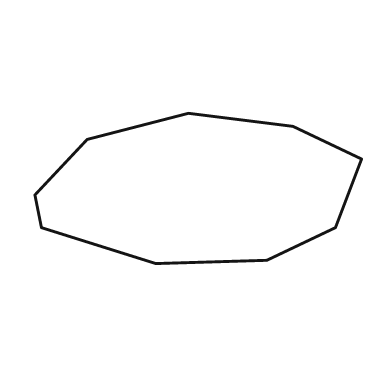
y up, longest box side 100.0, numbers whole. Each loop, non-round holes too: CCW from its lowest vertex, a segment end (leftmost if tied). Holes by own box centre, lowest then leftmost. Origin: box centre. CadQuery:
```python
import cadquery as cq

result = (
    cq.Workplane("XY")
    .moveTo(-13.0, -23.0)
    .lineTo(21.0, -22.0)
    .lineTo(42.0, -12.0)
    .lineTo(50.0, 9.0)
    .lineTo(29.0, 19.0)
    .lineTo(-3.0, 23.0)
    .lineTo(-34.0, 15.0)
    .lineTo(-50.0, -2.0)
    .lineTo(-48.0, -12.0)
    .close()
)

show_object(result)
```